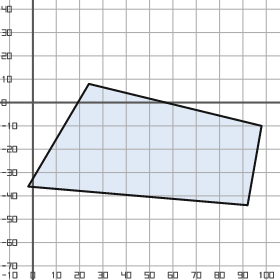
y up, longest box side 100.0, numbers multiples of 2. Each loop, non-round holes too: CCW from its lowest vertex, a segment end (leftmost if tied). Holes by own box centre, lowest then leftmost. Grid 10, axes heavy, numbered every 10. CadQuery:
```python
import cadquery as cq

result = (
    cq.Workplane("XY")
    .moveTo(92.0, -44.0)
    .lineTo(98.0, -10.0)
    .lineTo(24.0, 8.0)
    .lineTo(-2.0, -36.0)
    .close()
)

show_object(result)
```